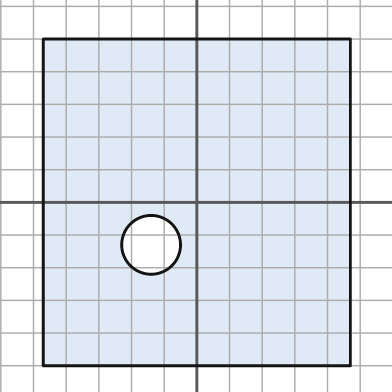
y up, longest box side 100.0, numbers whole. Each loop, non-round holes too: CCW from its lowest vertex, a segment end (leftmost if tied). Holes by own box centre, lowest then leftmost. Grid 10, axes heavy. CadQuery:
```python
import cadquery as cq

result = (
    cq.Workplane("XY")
    .moveTo(-47.0, -50.0)
    .lineTo(47.0, -50.0)
    .lineTo(47.0, 50.0)
    .lineTo(-47.0, 50.0)
    .close()
    .moveTo(-14.0, -13.0)
    .circle(9.0)
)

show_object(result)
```